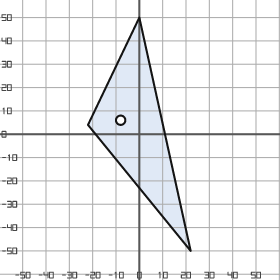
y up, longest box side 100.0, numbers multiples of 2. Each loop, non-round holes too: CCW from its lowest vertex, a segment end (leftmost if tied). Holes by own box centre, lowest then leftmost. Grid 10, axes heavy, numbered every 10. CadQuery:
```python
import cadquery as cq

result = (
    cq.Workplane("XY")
    .moveTo(22.0, -50.0)
    .lineTo(0.0, 50.0)
    .lineTo(-22.0, 4.0)
    .close()
    .moveTo(-8.0, 6.0)
    .circle(2.0)
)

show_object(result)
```